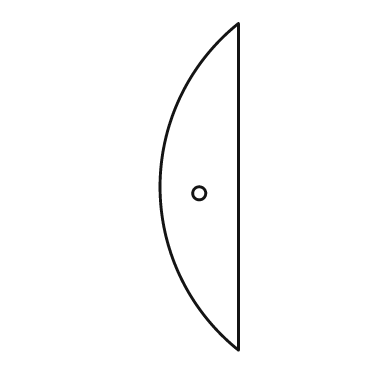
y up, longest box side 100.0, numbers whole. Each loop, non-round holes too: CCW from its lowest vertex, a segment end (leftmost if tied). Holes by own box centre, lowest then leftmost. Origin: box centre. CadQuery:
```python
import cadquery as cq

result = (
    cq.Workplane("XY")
    .moveTo(12.0, -50.0)
    .lineTo(12.0, 50.0)
    .threePointArc((-12.0, 0.0), (12.0, -50.0))
    .close()
    .moveTo(0.0, -2.0)
    .circle(2.0)
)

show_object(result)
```